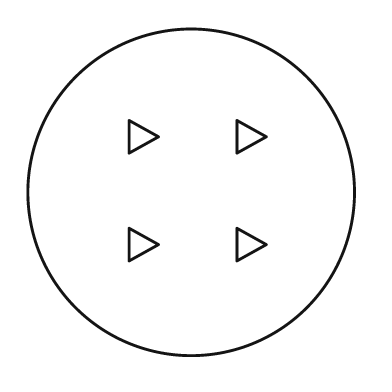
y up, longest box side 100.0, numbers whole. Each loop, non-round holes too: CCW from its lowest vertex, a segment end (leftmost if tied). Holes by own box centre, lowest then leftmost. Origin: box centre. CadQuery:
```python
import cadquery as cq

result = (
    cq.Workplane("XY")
    .moveTo(0.0, 0.0)
    .circle(50.0)
    .moveTo(-19.0, -21.0)
    .lineTo(-10.0, -16.0)
    .lineTo(-19.0, -11.0)
    .close()
    .moveTo(14.0, -21.0)
    .lineTo(23.0, -16.0)
    .lineTo(14.0, -11.0)
    .close()
    .moveTo(-19.0, 12.0)
    .lineTo(-10.0, 17.0)
    .lineTo(-19.0, 22.0)
    .close()
    .moveTo(14.0, 12.0)
    .lineTo(23.0, 17.0)
    .lineTo(14.0, 22.0)
    .close()
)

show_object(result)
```